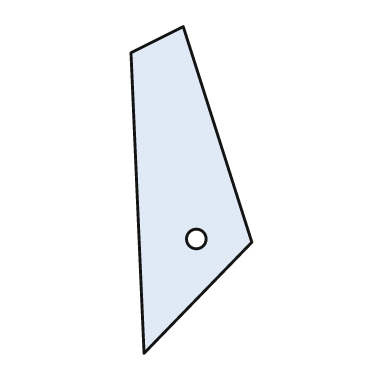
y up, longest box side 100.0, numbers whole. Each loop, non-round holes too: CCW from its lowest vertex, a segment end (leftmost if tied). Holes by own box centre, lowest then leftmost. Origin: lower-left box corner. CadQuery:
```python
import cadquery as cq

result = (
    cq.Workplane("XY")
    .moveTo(4.0, 0.0)
    .lineTo(37.0, 34.0)
    .lineTo(16.0, 100.0)
    .lineTo(0.0, 92.0)
    .close()
    .moveTo(20.0, 35.0)
    .circle(3.0)
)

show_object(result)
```